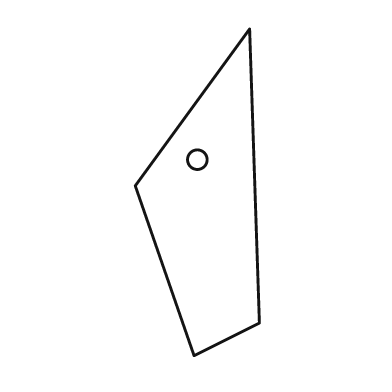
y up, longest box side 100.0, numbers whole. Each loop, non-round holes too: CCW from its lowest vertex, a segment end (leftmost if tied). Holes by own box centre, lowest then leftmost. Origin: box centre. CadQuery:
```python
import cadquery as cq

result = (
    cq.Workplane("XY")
    .moveTo(-1.0, -50.0)
    .lineTo(19.0, -40.0)
    .lineTo(16.0, 50.0)
    .lineTo(-19.0, 2.0)
    .close()
    .moveTo(0.0, 10.0)
    .circle(3.0)
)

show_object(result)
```